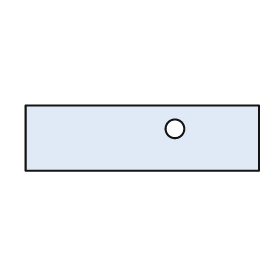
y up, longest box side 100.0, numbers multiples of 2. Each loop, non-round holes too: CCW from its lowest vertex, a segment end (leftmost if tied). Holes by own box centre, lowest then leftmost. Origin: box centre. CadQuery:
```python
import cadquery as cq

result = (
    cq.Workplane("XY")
    .moveTo(-50.0, -14.0)
    .lineTo(50.0, -14.0)
    .lineTo(50.0, 14.0)
    .lineTo(-50.0, 14.0)
    .close()
    .moveTo(14.0, 4.0)
    .circle(4.0)
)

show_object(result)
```